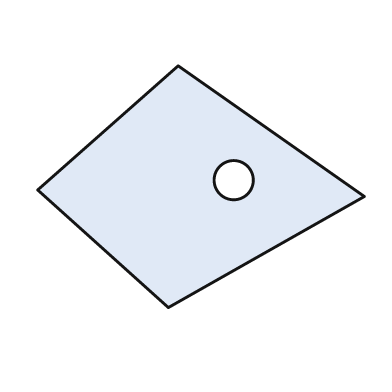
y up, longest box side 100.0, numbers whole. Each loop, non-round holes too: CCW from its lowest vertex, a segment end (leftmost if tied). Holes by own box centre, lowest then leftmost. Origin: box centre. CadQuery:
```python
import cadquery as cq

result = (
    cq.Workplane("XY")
    .moveTo(-10.0, -37.0)
    .lineTo(50.0, -3.0)
    .lineTo(-7.0, 37.0)
    .lineTo(-50.0, -1.0)
    .close()
    .moveTo(10.0, 2.0)
    .circle(6.0)
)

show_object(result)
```